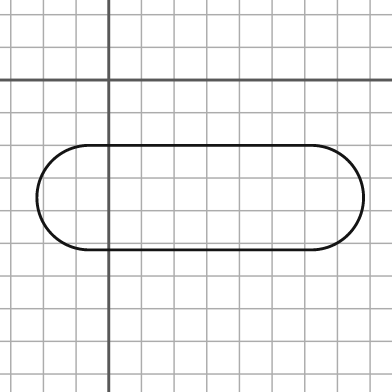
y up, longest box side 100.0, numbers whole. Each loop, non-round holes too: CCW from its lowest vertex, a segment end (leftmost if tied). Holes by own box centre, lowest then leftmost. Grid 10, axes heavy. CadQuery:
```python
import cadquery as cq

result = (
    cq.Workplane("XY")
    .moveTo(-6.0, -52.0)
    .lineTo(62.0, -52.0)
    .threePointArc((78.0, -36.0), (62.0, -20.0))
    .lineTo(-6.0, -20.0)
    .threePointArc((-22.0, -36.0), (-6.0, -52.0))
    .close()
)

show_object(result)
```